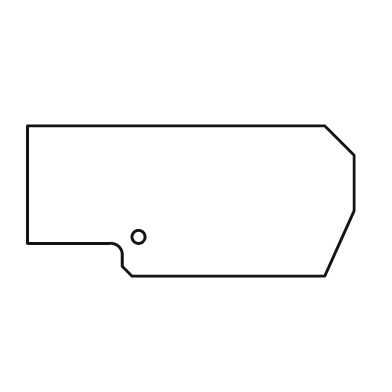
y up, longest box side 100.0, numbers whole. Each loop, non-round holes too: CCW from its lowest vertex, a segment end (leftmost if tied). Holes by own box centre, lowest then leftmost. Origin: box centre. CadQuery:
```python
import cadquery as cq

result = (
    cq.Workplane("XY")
    .moveTo(-18.0, -23.0)
    .lineTo(41.0, -23.0)
    .lineTo(50.0, -3.0)
    .lineTo(50.0, 14.0)
    .lineTo(41.0, 23.0)
    .lineTo(-50.0, 23.0)
    .lineTo(-50.0, -13.0)
    .lineTo(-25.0, -13.0)
    .threePointArc((-22.0, -14.0), (-21.0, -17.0))
    .lineTo(-21.0, -20.0)
    .close()
    .moveTo(-16.0, -11.0)
    .circle(2.0)
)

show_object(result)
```